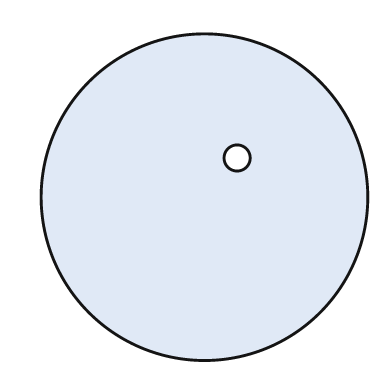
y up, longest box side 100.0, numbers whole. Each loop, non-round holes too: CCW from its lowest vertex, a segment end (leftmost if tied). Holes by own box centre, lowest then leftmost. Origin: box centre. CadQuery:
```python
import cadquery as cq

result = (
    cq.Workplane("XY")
    .moveTo(0.0, 0.0)
    .circle(50.0)
    .moveTo(10.0, 12.0)
    .circle(4.0)
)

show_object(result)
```